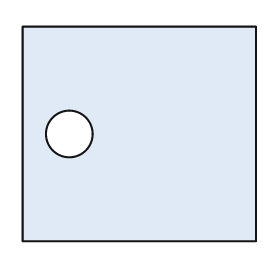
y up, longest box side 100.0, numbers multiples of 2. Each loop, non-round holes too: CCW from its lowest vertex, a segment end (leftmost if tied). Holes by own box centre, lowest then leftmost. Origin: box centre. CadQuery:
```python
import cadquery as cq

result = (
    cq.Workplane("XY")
    .moveTo(-50.0, -46.0)
    .lineTo(50.0, -46.0)
    .lineTo(50.0, 46.0)
    .lineTo(-50.0, 46.0)
    .close()
    .moveTo(-30.0, 0.0)
    .circle(10.0)
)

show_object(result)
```